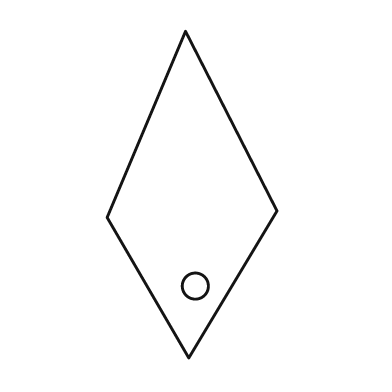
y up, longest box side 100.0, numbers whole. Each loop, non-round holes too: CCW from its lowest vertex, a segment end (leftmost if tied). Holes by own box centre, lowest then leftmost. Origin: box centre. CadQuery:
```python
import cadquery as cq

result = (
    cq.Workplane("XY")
    .moveTo(-1.0, -50.0)
    .lineTo(26.0, -5.0)
    .lineTo(-2.0, 50.0)
    .lineTo(-26.0, -7.0)
    .close()
    .moveTo(1.0, -28.0)
    .circle(4.0)
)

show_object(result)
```